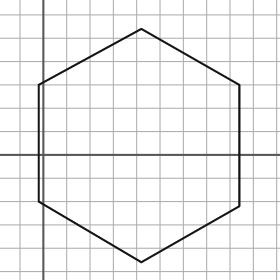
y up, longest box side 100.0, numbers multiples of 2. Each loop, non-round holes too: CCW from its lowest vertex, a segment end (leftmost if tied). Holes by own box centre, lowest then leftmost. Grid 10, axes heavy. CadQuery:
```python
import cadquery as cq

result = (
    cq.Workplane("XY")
    .moveTo(42.0, -46.0)
    .lineTo(84.0, -22.0)
    .lineTo(84.0, 30.0)
    .lineTo(42.0, 54.0)
    .lineTo(-2.0, 30.0)
    .lineTo(-2.0, -20.0)
    .close()
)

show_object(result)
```